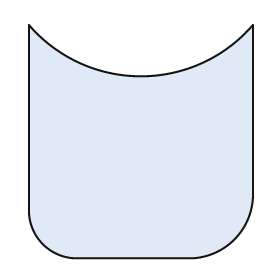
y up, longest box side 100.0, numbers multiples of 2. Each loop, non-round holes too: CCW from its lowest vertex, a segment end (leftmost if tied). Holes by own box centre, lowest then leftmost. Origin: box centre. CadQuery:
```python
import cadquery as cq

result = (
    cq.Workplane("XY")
    .moveTo(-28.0, -50.0)
    .lineTo(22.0, -50.0)
    .threePointArc((40.0, -42.0), (48.0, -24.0))
    .lineTo(48.0, 50.0)
    .threePointArc((0.0, 28.0), (-48.0, 50.0))
    .lineTo(-48.0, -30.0)
    .threePointArc((-42.0, -44.0), (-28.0, -50.0))
    .close()
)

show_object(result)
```